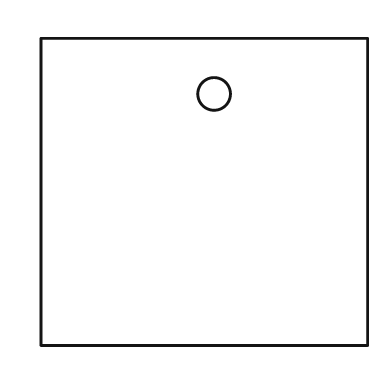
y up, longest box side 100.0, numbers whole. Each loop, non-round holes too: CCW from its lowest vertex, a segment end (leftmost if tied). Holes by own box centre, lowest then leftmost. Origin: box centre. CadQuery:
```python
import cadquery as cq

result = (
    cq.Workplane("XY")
    .moveTo(-50.0, -47.0)
    .lineTo(50.0, -47.0)
    .lineTo(50.0, 47.0)
    .lineTo(-50.0, 47.0)
    .close()
    .moveTo(3.0, 30.0)
    .circle(5.0)
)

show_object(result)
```